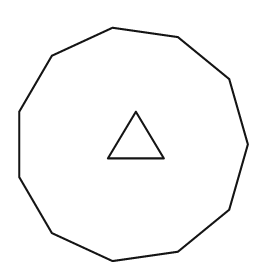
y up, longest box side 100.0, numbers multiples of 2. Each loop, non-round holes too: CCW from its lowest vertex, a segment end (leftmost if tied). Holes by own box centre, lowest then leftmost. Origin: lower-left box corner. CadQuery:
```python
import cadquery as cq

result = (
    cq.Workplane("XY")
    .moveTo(40.0, 0.0)
    .lineTo(68.0, 4.0)
    .lineTo(90.0, 22.0)
    .lineTo(98.0, 50.0)
    .lineTo(90.0, 78.0)
    .lineTo(68.0, 96.0)
    .lineTo(40.0, 100.0)
    .lineTo(14.0, 88.0)
    .lineTo(0.0, 64.0)
    .lineTo(0.0, 36.0)
    .lineTo(14.0, 12.0)
    .close()
    .moveTo(38.0, 44.0)
    .lineTo(62.0, 44.0)
    .lineTo(50.0, 64.0)
    .close()
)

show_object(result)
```